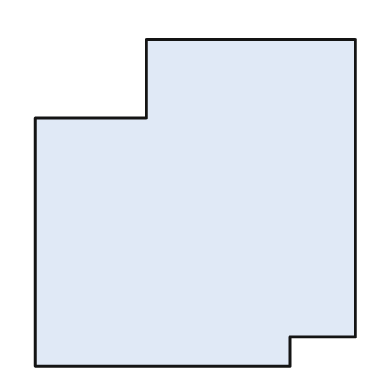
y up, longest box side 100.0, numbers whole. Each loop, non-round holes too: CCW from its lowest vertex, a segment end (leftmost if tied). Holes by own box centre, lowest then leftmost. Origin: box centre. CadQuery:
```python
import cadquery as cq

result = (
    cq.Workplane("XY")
    .moveTo(-49.0, -50.0)
    .lineTo(29.0, -50.0)
    .lineTo(29.0, -41.0)
    .lineTo(49.0, -41.0)
    .lineTo(49.0, 50.0)
    .lineTo(-15.0, 50.0)
    .lineTo(-15.0, 26.0)
    .lineTo(-49.0, 26.0)
    .close()
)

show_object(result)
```